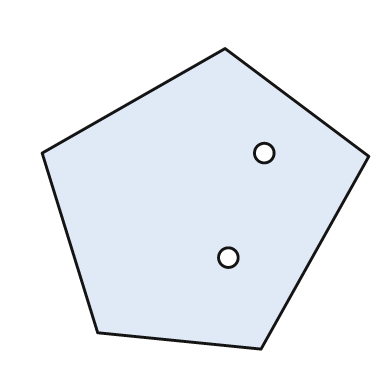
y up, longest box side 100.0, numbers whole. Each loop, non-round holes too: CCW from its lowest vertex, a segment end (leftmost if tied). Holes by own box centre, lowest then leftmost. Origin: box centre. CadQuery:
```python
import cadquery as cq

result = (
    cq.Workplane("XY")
    .moveTo(17.0, -46.0)
    .lineTo(50.0, 13.0)
    .lineTo(6.0, 46.0)
    .lineTo(-50.0, 14.0)
    .lineTo(-33.0, -41.0)
    .close()
    .moveTo(7.0, -18.0)
    .circle(3.0)
    .moveTo(18.0, 14.0)
    .circle(3.0)
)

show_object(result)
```